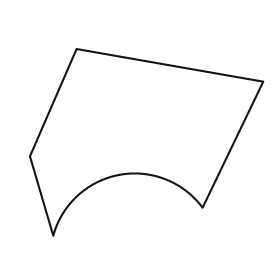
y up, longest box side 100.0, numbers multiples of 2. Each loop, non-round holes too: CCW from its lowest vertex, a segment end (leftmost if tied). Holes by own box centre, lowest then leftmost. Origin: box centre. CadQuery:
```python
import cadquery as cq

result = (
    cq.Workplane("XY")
    .moveTo(-40.0, -40.0)
    .threePointArc((-12.0, -14.0), (24.0, -28.0))
    .lineTo(50.0, 26.0)
    .lineTo(-30.0, 40.0)
    .lineTo(-50.0, -6.0)
    .close()
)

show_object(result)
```